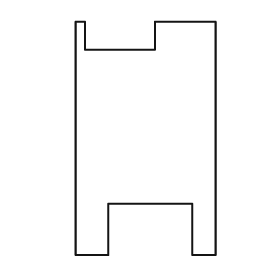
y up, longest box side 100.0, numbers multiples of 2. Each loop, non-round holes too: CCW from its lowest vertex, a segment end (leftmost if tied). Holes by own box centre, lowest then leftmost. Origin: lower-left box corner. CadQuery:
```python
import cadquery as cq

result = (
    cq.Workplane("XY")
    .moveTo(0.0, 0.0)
    .lineTo(14.0, 0.0)
    .lineTo(14.0, 22.0)
    .lineTo(50.0, 22.0)
    .lineTo(50.0, 0.0)
    .lineTo(60.0, 0.0)
    .lineTo(60.0, 100.0)
    .lineTo(34.0, 100.0)
    .lineTo(34.0, 88.0)
    .lineTo(4.0, 88.0)
    .lineTo(4.0, 100.0)
    .lineTo(0.0, 100.0)
    .close()
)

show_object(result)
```